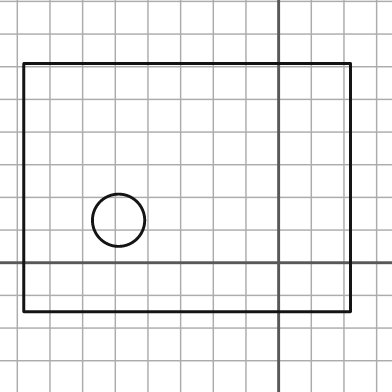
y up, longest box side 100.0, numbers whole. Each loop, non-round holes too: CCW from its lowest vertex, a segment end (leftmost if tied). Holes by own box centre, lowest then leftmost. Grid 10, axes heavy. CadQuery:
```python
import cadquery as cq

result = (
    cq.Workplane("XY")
    .moveTo(-78.0, -15.0)
    .lineTo(22.0, -15.0)
    .lineTo(22.0, 61.0)
    .lineTo(-78.0, 61.0)
    .close()
    .moveTo(-49.0, 13.0)
    .circle(8.0)
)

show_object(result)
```